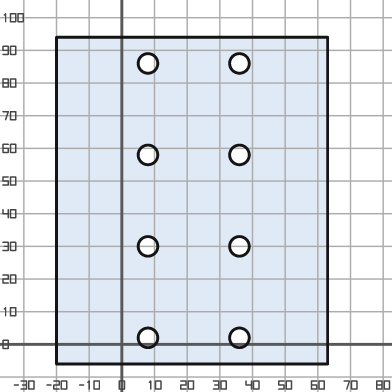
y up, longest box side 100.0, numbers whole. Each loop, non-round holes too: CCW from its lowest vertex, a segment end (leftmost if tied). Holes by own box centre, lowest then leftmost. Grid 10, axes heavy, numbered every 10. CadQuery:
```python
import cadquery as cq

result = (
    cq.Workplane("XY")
    .moveTo(-20.0, -6.0)
    .lineTo(63.0, -6.0)
    .lineTo(63.0, 94.0)
    .lineTo(-20.0, 94.0)
    .close()
    .moveTo(8.0, 2.0)
    .circle(3.0)
    .moveTo(36.0, 2.0)
    .circle(3.0)
    .moveTo(8.0, 30.0)
    .circle(3.0)
    .moveTo(36.0, 30.0)
    .circle(3.0)
    .moveTo(8.0, 58.0)
    .circle(3.0)
    .moveTo(36.0, 58.0)
    .circle(3.0)
    .moveTo(8.0, 86.0)
    .circle(3.0)
    .moveTo(36.0, 86.0)
    .circle(3.0)
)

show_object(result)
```